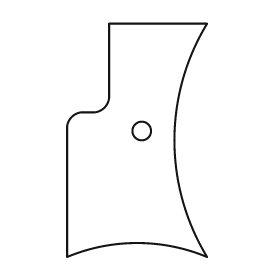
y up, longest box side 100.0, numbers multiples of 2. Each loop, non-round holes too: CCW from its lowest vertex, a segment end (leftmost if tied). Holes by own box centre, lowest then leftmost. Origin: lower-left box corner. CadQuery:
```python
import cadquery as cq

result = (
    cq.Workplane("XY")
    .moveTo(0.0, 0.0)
    .threePointArc((30.0, 6.0), (60.0, 0.0))
    .threePointArc((46.0, 50.0), (60.0, 100.0))
    .lineTo(18.0, 100.0)
    .lineTo(18.0, 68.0)
    .threePointArc((16.0, 64.0), (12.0, 62.0))
    .lineTo(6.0, 62.0)
    .threePointArc((2.0, 60.0), (0.0, 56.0))
    .close()
    .moveTo(32.0, 54.0)
    .circle(4.0)
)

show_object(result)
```